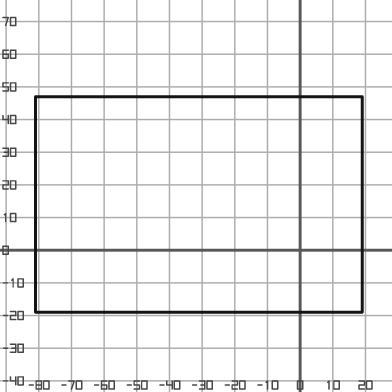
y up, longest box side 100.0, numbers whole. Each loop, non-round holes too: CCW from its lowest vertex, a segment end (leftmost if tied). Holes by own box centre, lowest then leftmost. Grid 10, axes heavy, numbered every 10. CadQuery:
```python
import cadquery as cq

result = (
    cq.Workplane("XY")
    .moveTo(-81.0, -19.0)
    .lineTo(19.0, -19.0)
    .lineTo(19.0, 47.0)
    .lineTo(-81.0, 47.0)
    .close()
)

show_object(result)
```